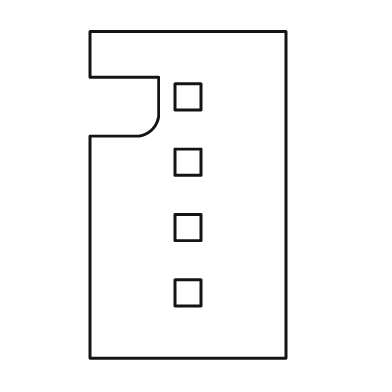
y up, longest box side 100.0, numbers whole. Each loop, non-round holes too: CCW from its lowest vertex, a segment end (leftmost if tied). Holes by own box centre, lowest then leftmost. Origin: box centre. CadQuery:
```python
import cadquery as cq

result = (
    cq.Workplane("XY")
    .moveTo(-30.0, -50.0)
    .lineTo(30.0, -50.0)
    .lineTo(30.0, 50.0)
    .lineTo(-30.0, 50.0)
    .lineTo(-30.0, 36.0)
    .lineTo(-9.0, 36.0)
    .lineTo(-9.0, 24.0)
    .threePointArc((-11.0, 20.0), (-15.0, 18.0))
    .lineTo(-30.0, 18.0)
    .close()
    .moveTo(-4.0, -34.0)
    .lineTo(4.0, -34.0)
    .lineTo(4.0, -26.0)
    .lineTo(-4.0, -26.0)
    .close()
    .moveTo(-4.0, -14.0)
    .lineTo(4.0, -14.0)
    .lineTo(4.0, -6.0)
    .lineTo(-4.0, -6.0)
    .close()
    .moveTo(-4.0, 6.0)
    .lineTo(4.0, 6.0)
    .lineTo(4.0, 14.0)
    .lineTo(-4.0, 14.0)
    .close()
    .moveTo(-4.0, 26.0)
    .lineTo(4.0, 26.0)
    .lineTo(4.0, 34.0)
    .lineTo(-4.0, 34.0)
    .close()
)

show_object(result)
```